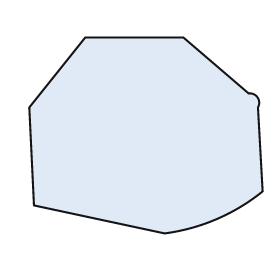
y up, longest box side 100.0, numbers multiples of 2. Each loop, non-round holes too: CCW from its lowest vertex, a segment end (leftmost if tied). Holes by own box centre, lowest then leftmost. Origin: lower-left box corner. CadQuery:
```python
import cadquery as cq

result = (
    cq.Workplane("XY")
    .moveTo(58.0, 0.0)
    .threePointArc((80.0, 6.0), (100.0, 18.0))
    .lineTo(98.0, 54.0)
    .threePointArc((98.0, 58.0), (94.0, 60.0))
    .lineTo(66.0, 84.0)
    .lineTo(24.0, 84.0)
    .lineTo(0.0, 54.0)
    .lineTo(2.0, 12.0)
    .close()
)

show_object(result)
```